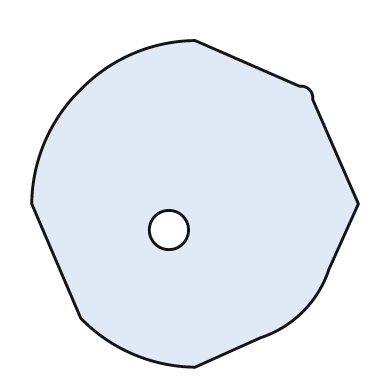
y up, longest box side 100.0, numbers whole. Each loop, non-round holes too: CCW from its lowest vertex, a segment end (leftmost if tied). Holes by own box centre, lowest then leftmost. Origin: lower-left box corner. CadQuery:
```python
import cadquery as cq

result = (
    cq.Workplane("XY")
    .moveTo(50.0, 0.0)
    .lineTo(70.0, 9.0)
    .threePointArc((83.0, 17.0), (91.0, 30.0))
    .lineTo(100.0, 50.0)
    .lineTo(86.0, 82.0)
    .threePointArc((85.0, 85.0), (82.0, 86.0))
    .lineTo(50.0, 100.0)
    .threePointArc((31.0, 96.0), (15.0, 85.0))
    .threePointArc((4.0, 69.0), (0.0, 50.0))
    .lineTo(15.0, 15.0)
    .threePointArc((31.0, 4.0), (50.0, 0.0))
    .close()
    .moveTo(42.0, 42.0)
    .circle(6.0)
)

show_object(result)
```